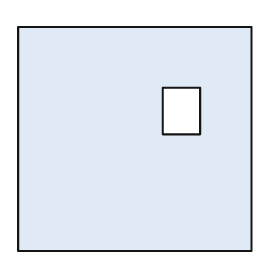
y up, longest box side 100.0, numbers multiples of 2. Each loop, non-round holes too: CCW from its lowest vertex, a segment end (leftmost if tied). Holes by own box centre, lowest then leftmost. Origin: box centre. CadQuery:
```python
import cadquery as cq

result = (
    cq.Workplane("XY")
    .moveTo(-50.0, -48.0)
    .lineTo(50.0, -48.0)
    .lineTo(50.0, 48.0)
    .lineTo(-50.0, 48.0)
    .close()
    .moveTo(12.0, 2.0)
    .lineTo(28.0, 2.0)
    .lineTo(28.0, 22.0)
    .lineTo(12.0, 22.0)
    .close()
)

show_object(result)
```